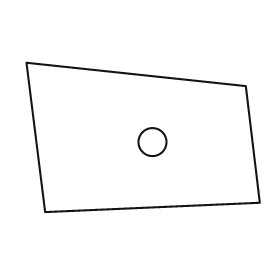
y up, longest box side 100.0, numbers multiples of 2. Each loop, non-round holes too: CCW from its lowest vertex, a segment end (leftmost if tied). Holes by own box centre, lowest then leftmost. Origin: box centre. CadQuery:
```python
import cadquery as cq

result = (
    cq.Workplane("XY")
    .moveTo(-42.0, -32.0)
    .lineTo(50.0, -28.0)
    .lineTo(44.0, 22.0)
    .lineTo(-50.0, 32.0)
    .close()
    .moveTo(4.0, -2.0)
    .circle(6.0)
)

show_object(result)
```